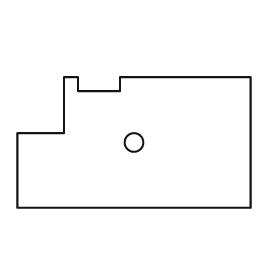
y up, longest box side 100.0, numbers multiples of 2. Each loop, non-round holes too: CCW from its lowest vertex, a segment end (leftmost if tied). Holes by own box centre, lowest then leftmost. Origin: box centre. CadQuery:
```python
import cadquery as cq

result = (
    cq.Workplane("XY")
    .moveTo(-50.0, -28.0)
    .lineTo(50.0, -28.0)
    .lineTo(50.0, 28.0)
    .lineTo(-6.0, 28.0)
    .lineTo(-6.0, 22.0)
    .lineTo(-24.0, 22.0)
    .lineTo(-24.0, 28.0)
    .lineTo(-30.0, 28.0)
    .lineTo(-30.0, 4.0)
    .lineTo(-50.0, 4.0)
    .close()
    .moveTo(0.0, 0.0)
    .circle(4.0)
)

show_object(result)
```